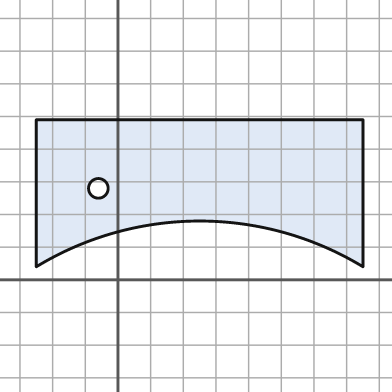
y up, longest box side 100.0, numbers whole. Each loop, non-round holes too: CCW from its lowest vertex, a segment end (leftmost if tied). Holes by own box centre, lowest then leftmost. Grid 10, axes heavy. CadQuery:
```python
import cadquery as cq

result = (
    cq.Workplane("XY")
    .moveTo(-25.0, 4.0)
    .threePointArc((25.0, 18.0), (75.0, 4.0))
    .lineTo(75.0, 49.0)
    .lineTo(-25.0, 49.0)
    .close()
    .moveTo(-6.0, 28.0)
    .circle(3.0)
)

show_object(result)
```